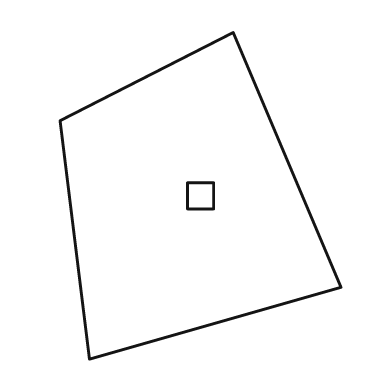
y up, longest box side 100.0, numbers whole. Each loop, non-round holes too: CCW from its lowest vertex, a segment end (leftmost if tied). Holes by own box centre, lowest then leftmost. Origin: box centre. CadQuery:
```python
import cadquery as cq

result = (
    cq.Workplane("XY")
    .moveTo(-34.0, -50.0)
    .lineTo(43.0, -28.0)
    .lineTo(10.0, 50.0)
    .lineTo(-43.0, 23.0)
    .close()
    .moveTo(-4.0, -4.0)
    .lineTo(4.0, -4.0)
    .lineTo(4.0, 4.0)
    .lineTo(-4.0, 4.0)
    .close()
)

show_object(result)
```